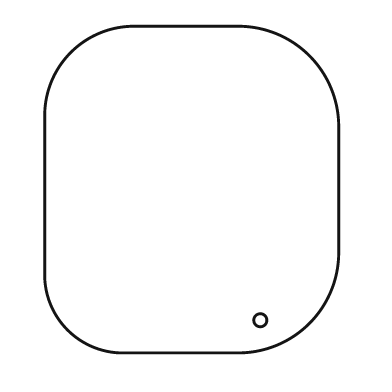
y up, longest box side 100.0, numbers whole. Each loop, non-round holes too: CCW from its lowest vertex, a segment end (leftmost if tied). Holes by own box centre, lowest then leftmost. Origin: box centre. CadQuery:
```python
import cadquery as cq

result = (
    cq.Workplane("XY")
    .moveTo(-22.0, -50.0)
    .lineTo(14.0, -50.0)
    .threePointArc((36.0, -41.0), (45.0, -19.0))
    .lineTo(45.0, 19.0)
    .threePointArc((36.0, 41.0), (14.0, 50.0))
    .lineTo(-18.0, 50.0)
    .threePointArc((-37.0, 42.0), (-45.0, 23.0))
    .lineTo(-45.0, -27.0)
    .threePointArc((-38.0, -43.0), (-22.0, -50.0))
    .close()
    .moveTo(21.0, -40.0)
    .circle(2.0)
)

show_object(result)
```